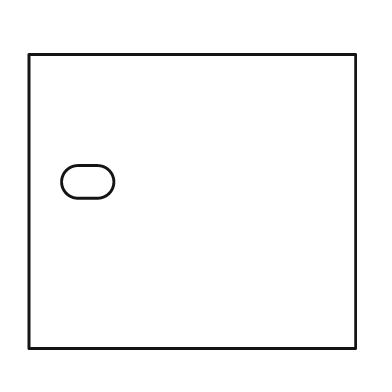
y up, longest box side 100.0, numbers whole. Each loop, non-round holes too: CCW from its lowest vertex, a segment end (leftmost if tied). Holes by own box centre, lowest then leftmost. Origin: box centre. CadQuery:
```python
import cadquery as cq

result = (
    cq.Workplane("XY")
    .moveTo(-50.0, -45.0)
    .lineTo(50.0, -45.0)
    .lineTo(50.0, 45.0)
    .lineTo(-50.0, 45.0)
    .close()
    .moveTo(-35.0, 1.0)
    .lineTo(-29.0, 1.0)
    .threePointArc((-24.0, 6.0), (-29.0, 11.0))
    .lineTo(-35.0, 11.0)
    .threePointArc((-40.0, 6.0), (-35.0, 1.0))
    .close()
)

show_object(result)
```